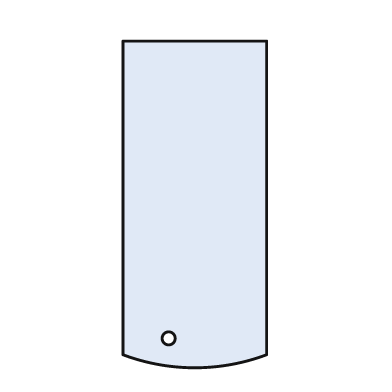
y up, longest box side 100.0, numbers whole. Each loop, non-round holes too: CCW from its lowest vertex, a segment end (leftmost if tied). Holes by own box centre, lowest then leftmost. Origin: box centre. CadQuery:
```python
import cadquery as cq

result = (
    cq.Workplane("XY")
    .moveTo(-22.0, -46.0)
    .threePointArc((0.0, -50.0), (22.0, -46.0))
    .lineTo(22.0, 50.0)
    .lineTo(-22.0, 50.0)
    .close()
    .moveTo(-8.0, -41.0)
    .circle(2.0)
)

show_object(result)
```